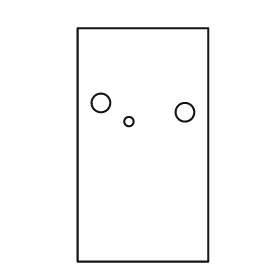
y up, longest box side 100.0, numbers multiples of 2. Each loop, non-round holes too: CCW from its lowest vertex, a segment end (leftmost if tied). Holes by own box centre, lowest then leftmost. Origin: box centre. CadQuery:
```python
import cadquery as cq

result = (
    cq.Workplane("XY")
    .moveTo(-28.0, -50.0)
    .lineTo(28.0, -50.0)
    .lineTo(28.0, 50.0)
    .lineTo(-28.0, 50.0)
    .close()
    .moveTo(-6.0, 10.0)
    .circle(2.0)
    .moveTo(18.0, 14.0)
    .circle(4.0)
    .moveTo(-18.0, 18.0)
    .circle(4.0)
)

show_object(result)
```